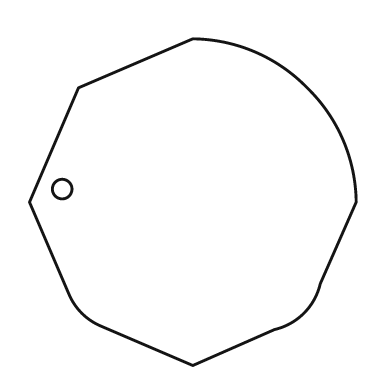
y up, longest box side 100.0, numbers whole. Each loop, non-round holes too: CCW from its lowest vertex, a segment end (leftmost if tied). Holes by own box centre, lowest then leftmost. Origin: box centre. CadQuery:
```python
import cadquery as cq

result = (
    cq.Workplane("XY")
    .moveTo(0.0, -50.0)
    .lineTo(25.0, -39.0)
    .threePointArc((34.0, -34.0), (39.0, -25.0))
    .lineTo(50.0, 0.0)
    .threePointArc((46.0, 19.0), (35.0, 35.0))
    .threePointArc((19.0, 46.0), (0.0, 50.0))
    .lineTo(-35.0, 35.0)
    .lineTo(-50.0, 0.0)
    .lineTo(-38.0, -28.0)
    .threePointArc((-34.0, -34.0), (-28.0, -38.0))
    .close()
    .moveTo(-40.0, 4.0)
    .circle(3.0)
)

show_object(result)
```